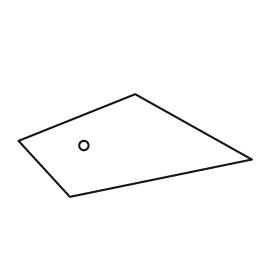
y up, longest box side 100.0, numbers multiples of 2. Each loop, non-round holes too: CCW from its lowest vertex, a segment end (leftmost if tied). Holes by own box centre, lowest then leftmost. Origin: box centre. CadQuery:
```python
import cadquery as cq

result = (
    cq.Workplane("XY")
    .moveTo(-28.0, -22.0)
    .lineTo(50.0, -6.0)
    .lineTo(0.0, 22.0)
    .lineTo(-50.0, 2.0)
    .close()
    .moveTo(-22.0, 0.0)
    .circle(2.0)
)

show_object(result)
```